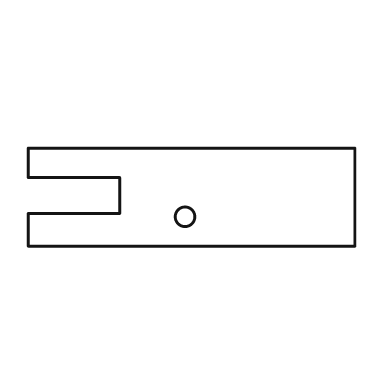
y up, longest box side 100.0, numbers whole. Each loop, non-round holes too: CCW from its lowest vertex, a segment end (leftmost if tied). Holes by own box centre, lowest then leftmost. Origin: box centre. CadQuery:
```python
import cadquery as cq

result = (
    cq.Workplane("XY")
    .moveTo(-50.0, -15.0)
    .lineTo(50.0, -15.0)
    .lineTo(50.0, 15.0)
    .lineTo(-50.0, 15.0)
    .lineTo(-50.0, 6.0)
    .lineTo(-22.0, 6.0)
    .lineTo(-22.0, -5.0)
    .lineTo(-50.0, -5.0)
    .close()
    .moveTo(-2.0, -6.0)
    .circle(3.0)
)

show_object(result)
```